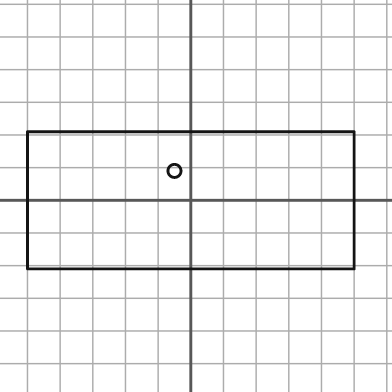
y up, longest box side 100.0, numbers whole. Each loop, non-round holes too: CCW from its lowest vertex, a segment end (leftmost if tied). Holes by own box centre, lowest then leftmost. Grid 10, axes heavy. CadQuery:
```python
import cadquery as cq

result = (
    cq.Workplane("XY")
    .moveTo(-50.0, -21.0)
    .lineTo(50.0, -21.0)
    .lineTo(50.0, 21.0)
    .lineTo(-50.0, 21.0)
    .close()
    .moveTo(-5.0, 9.0)
    .circle(2.0)
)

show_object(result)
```